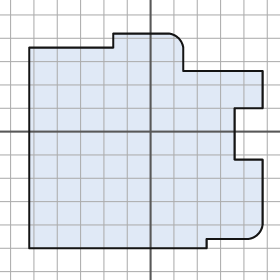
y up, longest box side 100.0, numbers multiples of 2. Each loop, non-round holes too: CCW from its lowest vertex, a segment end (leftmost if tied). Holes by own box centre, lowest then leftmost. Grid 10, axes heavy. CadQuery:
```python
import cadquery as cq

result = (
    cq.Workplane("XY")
    .moveTo(-52.0, -50.0)
    .lineTo(24.0, -50.0)
    .lineTo(24.0, -46.0)
    .lineTo(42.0, -46.0)
    .threePointArc((46.0, -44.0), (48.0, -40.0))
    .lineTo(48.0, -12.0)
    .lineTo(36.0, -12.0)
    .lineTo(36.0, 10.0)
    .lineTo(48.0, 10.0)
    .lineTo(48.0, 26.0)
    .lineTo(14.0, 26.0)
    .lineTo(14.0, 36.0)
    .threePointArc((12.0, 40.0), (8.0, 42.0))
    .lineTo(-16.0, 42.0)
    .lineTo(-16.0, 36.0)
    .lineTo(-52.0, 36.0)
    .close()
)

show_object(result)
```